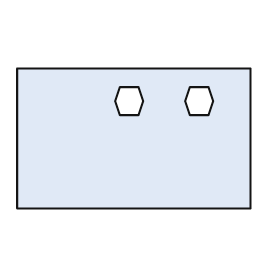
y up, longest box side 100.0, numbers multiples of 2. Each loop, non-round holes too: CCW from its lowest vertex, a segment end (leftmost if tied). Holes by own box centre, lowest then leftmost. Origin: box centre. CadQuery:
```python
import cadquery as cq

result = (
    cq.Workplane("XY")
    .moveTo(-50.0, -30.0)
    .lineTo(50.0, -30.0)
    .lineTo(50.0, 30.0)
    .lineTo(-50.0, 30.0)
    .close()
    .moveTo(-6.0, 10.0)
    .lineTo(2.0, 10.0)
    .lineTo(4.0, 16.0)
    .lineTo(2.0, 22.0)
    .lineTo(-6.0, 22.0)
    .lineTo(-8.0, 16.0)
    .close()
    .moveTo(24.0, 10.0)
    .lineTo(32.0, 10.0)
    .lineTo(34.0, 16.0)
    .lineTo(32.0, 22.0)
    .lineTo(24.0, 22.0)
    .lineTo(22.0, 16.0)
    .close()
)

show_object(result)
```